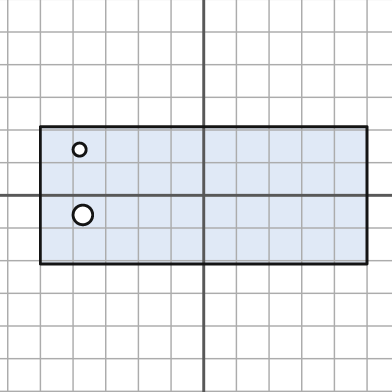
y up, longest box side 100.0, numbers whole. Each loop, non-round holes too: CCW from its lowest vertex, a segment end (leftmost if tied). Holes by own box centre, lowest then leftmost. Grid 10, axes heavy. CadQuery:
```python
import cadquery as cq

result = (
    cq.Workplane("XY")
    .moveTo(-50.0, -21.0)
    .lineTo(50.0, -21.0)
    .lineTo(50.0, 21.0)
    .lineTo(-50.0, 21.0)
    .close()
    .moveTo(-37.0, -6.0)
    .circle(3.0)
    .moveTo(-38.0, 14.0)
    .circle(2.0)
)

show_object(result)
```